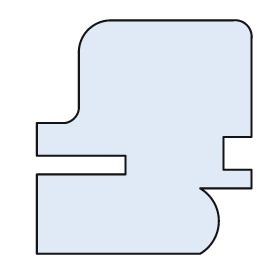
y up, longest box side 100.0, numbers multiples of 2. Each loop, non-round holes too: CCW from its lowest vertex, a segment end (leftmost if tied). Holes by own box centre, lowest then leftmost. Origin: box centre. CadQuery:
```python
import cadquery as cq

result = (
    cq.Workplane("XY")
    .moveTo(-46.0, -50.0)
    .lineTo(24.0, -50.0)
    .threePointArc((32.0, -36.0), (24.0, -22.0))
    .lineTo(46.0, -22.0)
    .lineTo(46.0, -14.0)
    .lineTo(34.0, -14.0)
    .lineTo(34.0, 0.0)
    .lineTo(46.0, 0.0)
    .lineTo(46.0, 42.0)
    .threePointArc((44.0, 48.0), (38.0, 50.0))
    .lineTo(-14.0, 50.0)
    .threePointArc((-24.0, 46.0), (-28.0, 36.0))
    .lineTo(-28.0, 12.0)
    .threePointArc((-30.0, 8.0), (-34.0, 6.0))
    .lineTo(-46.0, 6.0)
    .lineTo(-46.0, -8.0)
    .lineTo(-8.0, -8.0)
    .lineTo(-8.0, -16.0)
    .lineTo(-46.0, -16.0)
    .close()
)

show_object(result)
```